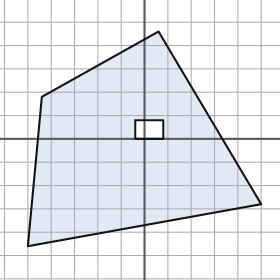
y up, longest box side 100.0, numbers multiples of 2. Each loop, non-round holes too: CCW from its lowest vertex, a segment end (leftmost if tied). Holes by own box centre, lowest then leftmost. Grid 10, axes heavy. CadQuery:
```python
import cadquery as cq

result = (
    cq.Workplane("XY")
    .moveTo(-50.0, -46.0)
    .lineTo(50.0, -28.0)
    .lineTo(6.0, 46.0)
    .lineTo(-44.0, 18.0)
    .close()
    .moveTo(-4.0, 0.0)
    .lineTo(8.0, 0.0)
    .lineTo(8.0, 8.0)
    .lineTo(-4.0, 8.0)
    .close()
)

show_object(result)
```